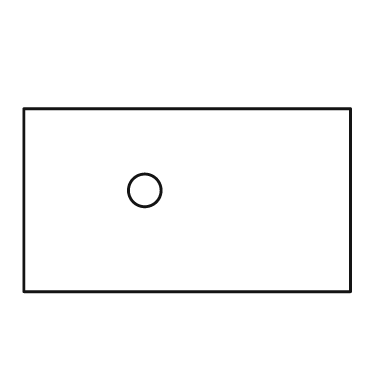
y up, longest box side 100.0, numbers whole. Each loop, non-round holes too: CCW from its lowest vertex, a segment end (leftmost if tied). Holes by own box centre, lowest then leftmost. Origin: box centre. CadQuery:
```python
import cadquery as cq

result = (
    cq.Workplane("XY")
    .moveTo(-50.0, -28.0)
    .lineTo(50.0, -28.0)
    .lineTo(50.0, 28.0)
    .lineTo(-50.0, 28.0)
    .close()
    .moveTo(-13.0, 3.0)
    .circle(5.0)
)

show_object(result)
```